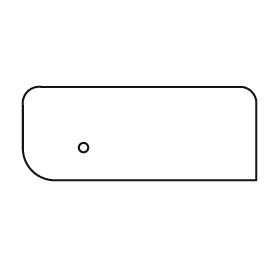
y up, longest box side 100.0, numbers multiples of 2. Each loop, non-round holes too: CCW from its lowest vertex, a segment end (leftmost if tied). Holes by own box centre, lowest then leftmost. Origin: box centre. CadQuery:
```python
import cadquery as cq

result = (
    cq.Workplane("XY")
    .moveTo(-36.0, -20.0)
    .lineTo(50.0, -20.0)
    .lineTo(50.0, 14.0)
    .threePointArc((48.0, 18.0), (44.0, 20.0))
    .lineTo(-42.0, 20.0)
    .threePointArc((-48.0, 18.0), (-50.0, 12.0))
    .lineTo(-50.0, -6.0)
    .threePointArc((-46.0, -16.0), (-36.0, -20.0))
    .close()
    .moveTo(-24.0, -6.0)
    .circle(2.0)
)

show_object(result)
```